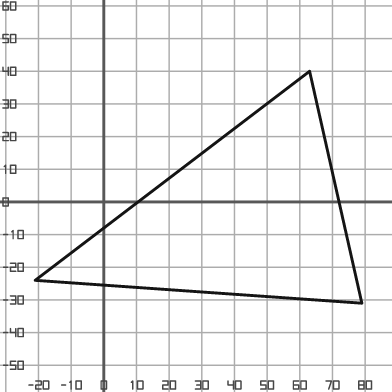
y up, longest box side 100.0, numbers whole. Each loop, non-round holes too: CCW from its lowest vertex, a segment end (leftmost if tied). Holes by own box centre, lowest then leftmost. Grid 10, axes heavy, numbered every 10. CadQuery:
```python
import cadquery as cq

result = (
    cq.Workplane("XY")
    .moveTo(79.0, -31.0)
    .lineTo(63.0, 40.0)
    .lineTo(-21.0, -24.0)
    .close()
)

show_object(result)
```